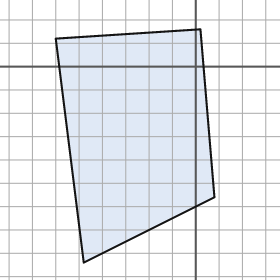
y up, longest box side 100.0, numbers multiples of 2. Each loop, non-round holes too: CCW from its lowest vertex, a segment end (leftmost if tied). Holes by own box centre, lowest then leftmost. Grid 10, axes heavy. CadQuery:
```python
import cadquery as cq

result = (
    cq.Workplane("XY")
    .moveTo(-48.0, -84.0)
    .lineTo(8.0, -56.0)
    .lineTo(2.0, 16.0)
    .lineTo(-60.0, 12.0)
    .close()
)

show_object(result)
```